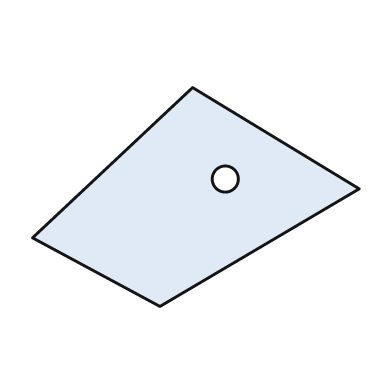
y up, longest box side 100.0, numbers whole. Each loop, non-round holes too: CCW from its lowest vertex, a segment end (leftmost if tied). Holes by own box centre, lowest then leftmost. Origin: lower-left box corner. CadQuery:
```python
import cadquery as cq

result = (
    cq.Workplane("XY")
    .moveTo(39.0, 0.0)
    .lineTo(100.0, 36.0)
    .lineTo(49.0, 67.0)
    .lineTo(0.0, 21.0)
    .close()
    .moveTo(59.0, 39.0)
    .circle(4.0)
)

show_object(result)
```